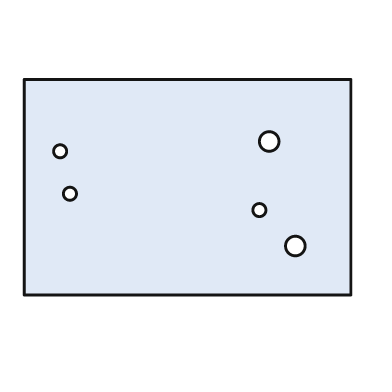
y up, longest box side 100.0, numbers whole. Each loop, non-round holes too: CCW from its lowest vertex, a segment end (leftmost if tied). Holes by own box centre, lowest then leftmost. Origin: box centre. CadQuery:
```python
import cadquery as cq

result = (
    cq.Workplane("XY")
    .moveTo(-50.0, -33.0)
    .lineTo(50.0, -33.0)
    .lineTo(50.0, 33.0)
    .lineTo(-50.0, 33.0)
    .close()
    .moveTo(33.0, -18.0)
    .circle(3.0)
    .moveTo(22.0, -7.0)
    .circle(2.0)
    .moveTo(-36.0, -2.0)
    .circle(2.0)
    .moveTo(-39.0, 11.0)
    .circle(2.0)
    .moveTo(25.0, 14.0)
    .circle(3.0)
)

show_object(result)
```